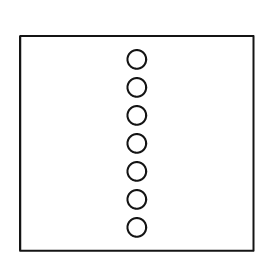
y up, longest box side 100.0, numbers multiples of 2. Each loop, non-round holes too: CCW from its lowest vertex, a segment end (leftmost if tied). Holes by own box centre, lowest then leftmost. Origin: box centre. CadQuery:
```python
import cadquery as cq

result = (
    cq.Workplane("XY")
    .moveTo(-50.0, -46.0)
    .lineTo(50.0, -46.0)
    .lineTo(50.0, 46.0)
    .lineTo(-50.0, 46.0)
    .close()
    .moveTo(0.0, -36.0)
    .circle(4.0)
    .moveTo(0.0, -24.0)
    .circle(4.0)
    .moveTo(0.0, -12.0)
    .circle(4.0)
    .moveTo(0.0, 0.0)
    .circle(4.0)
    .moveTo(0.0, 12.0)
    .circle(4.0)
    .moveTo(0.0, 24.0)
    .circle(4.0)
    .moveTo(0.0, 36.0)
    .circle(4.0)
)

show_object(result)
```